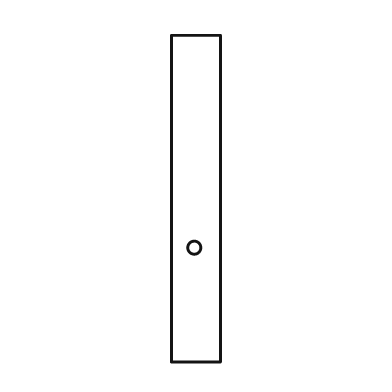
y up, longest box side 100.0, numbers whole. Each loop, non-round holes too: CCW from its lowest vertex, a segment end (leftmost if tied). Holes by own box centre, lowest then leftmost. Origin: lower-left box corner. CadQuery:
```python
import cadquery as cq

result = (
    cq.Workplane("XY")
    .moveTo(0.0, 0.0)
    .lineTo(15.0, 0.0)
    .lineTo(15.0, 100.0)
    .lineTo(0.0, 100.0)
    .close()
    .moveTo(7.0, 35.0)
    .circle(2.0)
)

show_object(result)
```